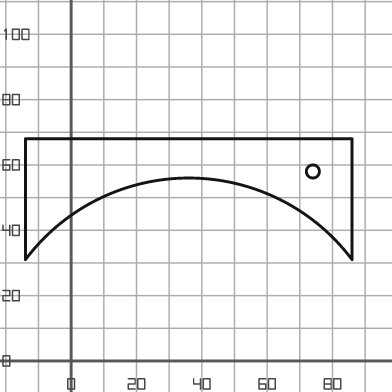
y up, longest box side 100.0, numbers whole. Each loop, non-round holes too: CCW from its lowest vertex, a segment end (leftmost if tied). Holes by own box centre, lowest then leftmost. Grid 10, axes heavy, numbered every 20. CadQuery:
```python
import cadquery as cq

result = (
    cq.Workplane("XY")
    .moveTo(-14.0, 31.0)
    .threePointArc((36.0, 56.0), (86.0, 31.0))
    .lineTo(86.0, 68.0)
    .lineTo(-14.0, 68.0)
    .close()
    .moveTo(74.0, 58.0)
    .circle(2.0)
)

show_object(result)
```